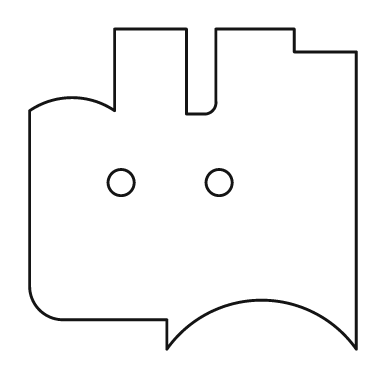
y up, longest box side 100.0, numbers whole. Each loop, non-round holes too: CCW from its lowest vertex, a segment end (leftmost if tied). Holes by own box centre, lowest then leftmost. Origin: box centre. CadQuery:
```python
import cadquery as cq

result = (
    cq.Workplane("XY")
    .moveTo(-8.0, -49.0)
    .threePointArc((21.0, -34.0), (50.0, -49.0))
    .lineTo(50.0, 42.0)
    .lineTo(31.0, 42.0)
    .lineTo(31.0, 49.0)
    .lineTo(7.0, 49.0)
    .lineTo(7.0, 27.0)
    .threePointArc((6.0, 24.0), (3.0, 23.0))
    .lineTo(-2.0, 23.0)
    .lineTo(-2.0, 49.0)
    .lineTo(-24.0, 49.0)
    .lineTo(-24.0, 24.0)
    .threePointArc((-37.0, 28.0), (-50.0, 24.0))
    .lineTo(-50.0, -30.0)
    .threePointArc((-47.0, -37.0), (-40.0, -40.0))
    .lineTo(-8.0, -40.0)
    .close()
    .moveTo(-22.0, 2.0)
    .circle(4.0)
    .moveTo(8.0, 2.0)
    .circle(4.0)
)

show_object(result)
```